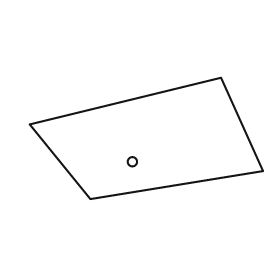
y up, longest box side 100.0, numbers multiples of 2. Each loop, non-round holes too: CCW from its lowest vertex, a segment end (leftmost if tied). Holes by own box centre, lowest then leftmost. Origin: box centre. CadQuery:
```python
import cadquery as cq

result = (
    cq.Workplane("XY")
    .moveTo(-24.0, -26.0)
    .lineTo(50.0, -14.0)
    .lineTo(32.0, 26.0)
    .lineTo(-50.0, 6.0)
    .close()
    .moveTo(-6.0, -10.0)
    .circle(2.0)
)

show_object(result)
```